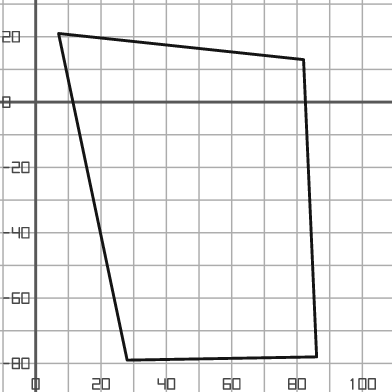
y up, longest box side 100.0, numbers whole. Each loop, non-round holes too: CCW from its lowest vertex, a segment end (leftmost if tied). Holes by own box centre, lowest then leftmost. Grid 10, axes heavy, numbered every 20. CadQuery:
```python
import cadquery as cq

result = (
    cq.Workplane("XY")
    .moveTo(28.0, -79.0)
    .lineTo(86.0, -78.0)
    .lineTo(82.0, 13.0)
    .lineTo(7.0, 21.0)
    .close()
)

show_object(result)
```